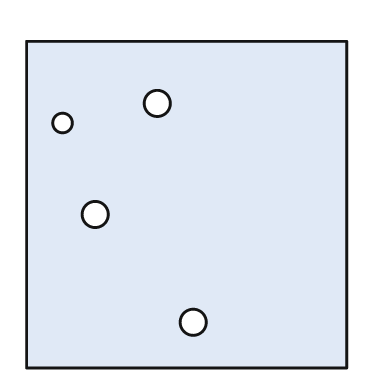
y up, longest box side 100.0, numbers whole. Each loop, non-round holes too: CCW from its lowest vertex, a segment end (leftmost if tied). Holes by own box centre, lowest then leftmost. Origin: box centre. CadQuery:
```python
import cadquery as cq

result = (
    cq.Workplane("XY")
    .moveTo(-49.0, -50.0)
    .lineTo(49.0, -50.0)
    .lineTo(49.0, 50.0)
    .lineTo(-49.0, 50.0)
    .close()
    .moveTo(2.0, -36.0)
    .circle(4.0)
    .moveTo(-28.0, -3.0)
    .circle(4.0)
    .moveTo(-38.0, 25.0)
    .circle(3.0)
    .moveTo(-9.0, 31.0)
    .circle(4.0)
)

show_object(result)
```